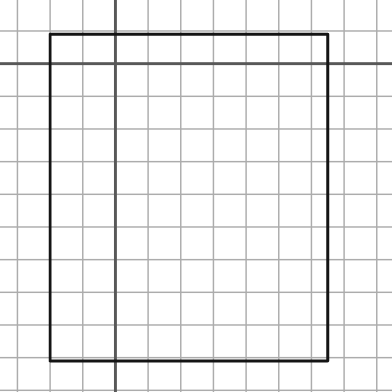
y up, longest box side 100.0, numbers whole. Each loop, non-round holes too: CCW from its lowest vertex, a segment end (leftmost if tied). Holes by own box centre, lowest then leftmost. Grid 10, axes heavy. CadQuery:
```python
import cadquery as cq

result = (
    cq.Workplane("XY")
    .moveTo(-20.0, -91.0)
    .lineTo(65.0, -91.0)
    .lineTo(65.0, 9.0)
    .lineTo(-20.0, 9.0)
    .close()
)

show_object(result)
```